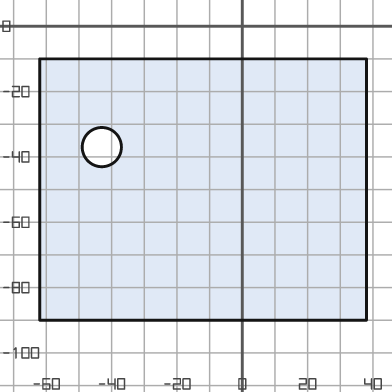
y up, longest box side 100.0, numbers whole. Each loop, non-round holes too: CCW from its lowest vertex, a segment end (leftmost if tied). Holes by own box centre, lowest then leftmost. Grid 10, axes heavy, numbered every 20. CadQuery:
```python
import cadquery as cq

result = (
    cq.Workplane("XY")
    .moveTo(-62.0, -90.0)
    .lineTo(38.0, -90.0)
    .lineTo(38.0, -10.0)
    .lineTo(-62.0, -10.0)
    .close()
    .moveTo(-43.0, -37.0)
    .circle(6.0)
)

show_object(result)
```